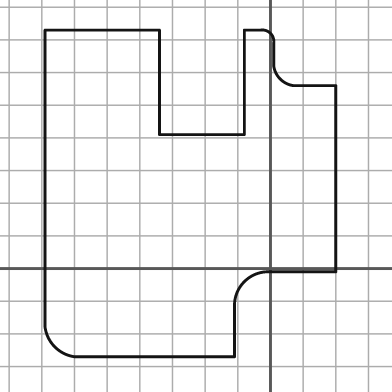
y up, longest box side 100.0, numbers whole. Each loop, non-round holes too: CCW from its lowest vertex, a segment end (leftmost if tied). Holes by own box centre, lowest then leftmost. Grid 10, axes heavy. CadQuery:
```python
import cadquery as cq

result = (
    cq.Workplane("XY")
    .moveTo(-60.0, -27.0)
    .lineTo(-11.0, -27.0)
    .lineTo(-11.0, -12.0)
    .threePointArc((-8.0, -4.0), (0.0, -1.0))
    .lineTo(20.0, -1.0)
    .lineTo(20.0, 56.0)
    .lineTo(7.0, 56.0)
    .threePointArc((3.0, 58.0), (1.0, 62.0))
    .lineTo(1.0, 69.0)
    .threePointArc((0.0, 72.0), (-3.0, 73.0))
    .lineTo(-8.0, 73.0)
    .lineTo(-8.0, 41.0)
    .lineTo(-34.0, 41.0)
    .lineTo(-34.0, 73.0)
    .lineTo(-69.0, 73.0)
    .lineTo(-69.0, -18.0)
    .threePointArc((-66.0, -24.0), (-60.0, -27.0))
    .close()
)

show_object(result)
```